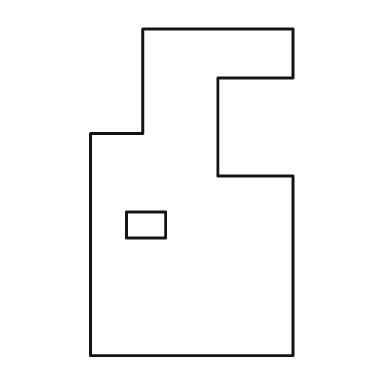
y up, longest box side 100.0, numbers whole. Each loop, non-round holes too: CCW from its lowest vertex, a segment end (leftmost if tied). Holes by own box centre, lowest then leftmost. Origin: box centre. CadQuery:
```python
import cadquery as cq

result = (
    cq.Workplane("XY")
    .moveTo(-31.0, -50.0)
    .lineTo(31.0, -50.0)
    .lineTo(31.0, 5.0)
    .lineTo(8.0, 5.0)
    .lineTo(8.0, 35.0)
    .lineTo(31.0, 35.0)
    .lineTo(31.0, 50.0)
    .lineTo(-15.0, 50.0)
    .lineTo(-15.0, 18.0)
    .lineTo(-31.0, 18.0)
    .close()
    .moveTo(-20.0, -14.0)
    .lineTo(-8.0, -14.0)
    .lineTo(-8.0, -6.0)
    .lineTo(-20.0, -6.0)
    .close()
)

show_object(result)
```